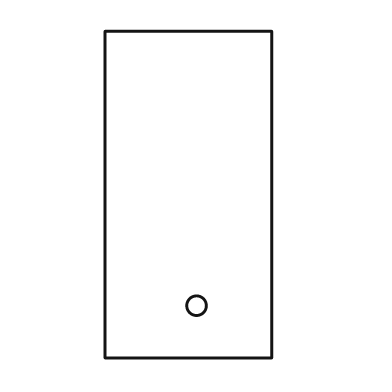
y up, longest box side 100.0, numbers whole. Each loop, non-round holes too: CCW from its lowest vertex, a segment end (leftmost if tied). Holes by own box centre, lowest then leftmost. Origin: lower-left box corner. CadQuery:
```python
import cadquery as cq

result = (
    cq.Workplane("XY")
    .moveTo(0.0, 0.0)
    .lineTo(51.0, 0.0)
    .lineTo(51.0, 100.0)
    .lineTo(0.0, 100.0)
    .close()
    .moveTo(28.0, 16.0)
    .circle(3.0)
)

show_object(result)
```